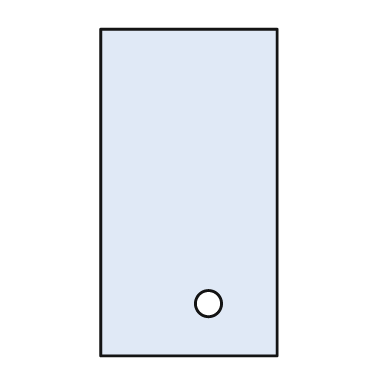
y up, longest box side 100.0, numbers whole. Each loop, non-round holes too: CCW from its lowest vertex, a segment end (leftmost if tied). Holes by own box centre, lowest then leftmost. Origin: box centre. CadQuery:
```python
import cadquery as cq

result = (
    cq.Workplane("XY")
    .moveTo(-27.0, -50.0)
    .lineTo(27.0, -50.0)
    .lineTo(27.0, 50.0)
    .lineTo(-27.0, 50.0)
    .close()
    .moveTo(6.0, -34.0)
    .circle(4.0)
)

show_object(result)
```